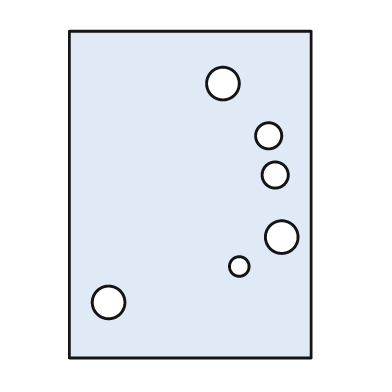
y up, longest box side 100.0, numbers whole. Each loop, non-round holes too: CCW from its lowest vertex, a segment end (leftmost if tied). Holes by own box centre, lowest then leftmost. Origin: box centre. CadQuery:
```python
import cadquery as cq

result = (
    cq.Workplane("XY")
    .moveTo(-37.0, -50.0)
    .lineTo(37.0, -50.0)
    .lineTo(37.0, 50.0)
    .lineTo(-37.0, 50.0)
    .close()
    .moveTo(-25.0, -33.0)
    .circle(5.0)
    .moveTo(15.0, -22.0)
    .circle(3.0)
    .moveTo(28.0, -13.0)
    .circle(5.0)
    .moveTo(26.0, 6.0)
    .circle(4.0)
    .moveTo(24.0, 18.0)
    .circle(4.0)
    .moveTo(10.0, 34.0)
    .circle(5.0)
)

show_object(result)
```